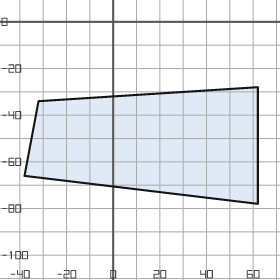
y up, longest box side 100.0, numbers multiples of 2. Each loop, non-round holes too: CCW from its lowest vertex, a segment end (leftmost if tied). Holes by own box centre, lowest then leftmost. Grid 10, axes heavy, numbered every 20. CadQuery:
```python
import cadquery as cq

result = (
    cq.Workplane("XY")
    .moveTo(62.0, -78.0)
    .lineTo(62.0, -28.0)
    .lineTo(-32.0, -34.0)
    .lineTo(-38.0, -66.0)
    .close()
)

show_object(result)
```